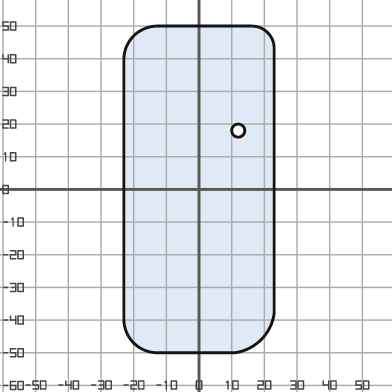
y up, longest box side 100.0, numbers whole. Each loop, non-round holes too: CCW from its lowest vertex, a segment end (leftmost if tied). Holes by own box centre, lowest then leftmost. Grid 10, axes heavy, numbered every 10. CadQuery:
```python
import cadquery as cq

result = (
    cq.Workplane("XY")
    .moveTo(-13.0, -50.0)
    .lineTo(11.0, -50.0)
    .threePointArc((19.0, -46.0), (23.0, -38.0))
    .lineTo(23.0, 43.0)
    .threePointArc((21.0, 48.0), (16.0, 50.0))
    .lineTo(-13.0, 50.0)
    .threePointArc((-20.0, 47.0), (-23.0, 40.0))
    .lineTo(-23.0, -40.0)
    .threePointArc((-20.0, -47.0), (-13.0, -50.0))
    .close()
    .moveTo(12.0, 18.0)
    .circle(2.0)
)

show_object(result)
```